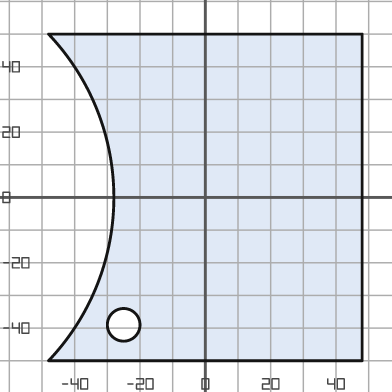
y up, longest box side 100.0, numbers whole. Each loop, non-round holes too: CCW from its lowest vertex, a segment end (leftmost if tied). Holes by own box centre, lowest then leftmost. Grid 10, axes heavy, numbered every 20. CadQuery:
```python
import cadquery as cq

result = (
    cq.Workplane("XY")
    .moveTo(-48.0, -50.0)
    .lineTo(48.0, -50.0)
    .lineTo(48.0, 50.0)
    .lineTo(-48.0, 50.0)
    .threePointArc((-28.0, 0.0), (-48.0, -50.0))
    .close()
    .moveTo(-25.0, -39.0)
    .circle(5.0)
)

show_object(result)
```